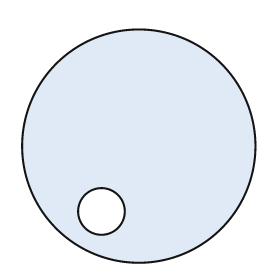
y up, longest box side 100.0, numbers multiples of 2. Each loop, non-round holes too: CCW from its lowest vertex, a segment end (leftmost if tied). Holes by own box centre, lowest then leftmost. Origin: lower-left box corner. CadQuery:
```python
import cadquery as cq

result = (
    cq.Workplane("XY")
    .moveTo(50.0, 50.0)
    .circle(50.0)
    .moveTo(34.0, 22.0)
    .circle(10.0)
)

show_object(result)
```